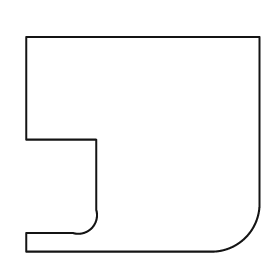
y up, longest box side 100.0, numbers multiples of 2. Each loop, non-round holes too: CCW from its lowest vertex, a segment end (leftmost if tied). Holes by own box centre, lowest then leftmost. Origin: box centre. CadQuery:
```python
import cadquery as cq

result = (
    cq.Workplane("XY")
    .moveTo(-50.0, -46.0)
    .lineTo(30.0, -46.0)
    .threePointArc((44.0, -40.0), (50.0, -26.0))
    .lineTo(50.0, 46.0)
    .lineTo(-50.0, 46.0)
    .lineTo(-50.0, 2.0)
    .lineTo(-20.0, 2.0)
    .lineTo(-20.0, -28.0)
    .threePointArc((-22.0, -36.0), (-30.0, -38.0))
    .lineTo(-50.0, -38.0)
    .close()
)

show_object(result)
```